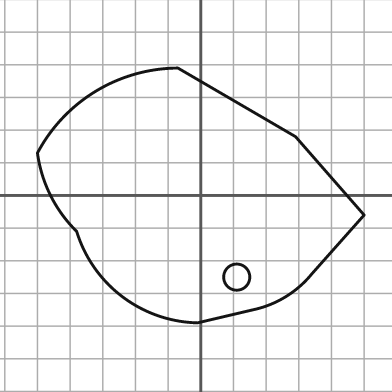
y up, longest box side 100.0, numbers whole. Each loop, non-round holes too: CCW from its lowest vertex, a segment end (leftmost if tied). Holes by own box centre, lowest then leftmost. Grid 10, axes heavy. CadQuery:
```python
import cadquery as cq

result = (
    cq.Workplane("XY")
    .moveTo(-1.0, -39.0)
    .lineTo(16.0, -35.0)
    .threePointArc((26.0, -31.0), (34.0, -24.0))
    .lineTo(50.0, -6.0)
    .lineTo(29.0, 18.0)
    .lineTo(-7.0, 39.0)
    .threePointArc((-32.0, 32.0), (-50.0, 13.0))
    .threePointArc((-46.0, 0.0), (-38.0, -11.0))
    .threePointArc((-24.0, -31.0), (-1.0, -39.0))
    .close()
    .moveTo(11.0, -25.0)
    .circle(4.0)
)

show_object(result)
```